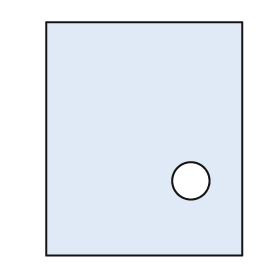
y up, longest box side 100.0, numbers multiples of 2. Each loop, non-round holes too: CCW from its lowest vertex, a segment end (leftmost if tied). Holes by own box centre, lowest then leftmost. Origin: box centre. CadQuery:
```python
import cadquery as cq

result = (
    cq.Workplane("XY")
    .moveTo(-42.0, -50.0)
    .lineTo(42.0, -50.0)
    .lineTo(42.0, 50.0)
    .lineTo(-42.0, 50.0)
    .close()
    .moveTo(20.0, -18.0)
    .circle(8.0)
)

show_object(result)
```